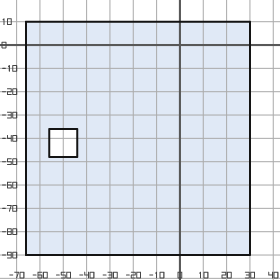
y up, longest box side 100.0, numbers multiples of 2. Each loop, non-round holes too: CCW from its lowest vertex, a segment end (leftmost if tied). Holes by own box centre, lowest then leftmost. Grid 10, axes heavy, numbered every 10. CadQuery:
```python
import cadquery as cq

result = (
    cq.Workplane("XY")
    .moveTo(-66.0, -90.0)
    .lineTo(30.0, -90.0)
    .lineTo(30.0, 10.0)
    .lineTo(-66.0, 10.0)
    .close()
    .moveTo(-56.0, -48.0)
    .lineTo(-44.0, -48.0)
    .lineTo(-44.0, -36.0)
    .lineTo(-56.0, -36.0)
    .close()
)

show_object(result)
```